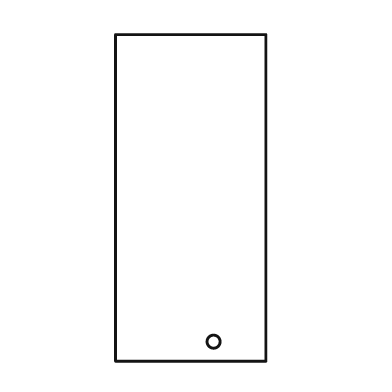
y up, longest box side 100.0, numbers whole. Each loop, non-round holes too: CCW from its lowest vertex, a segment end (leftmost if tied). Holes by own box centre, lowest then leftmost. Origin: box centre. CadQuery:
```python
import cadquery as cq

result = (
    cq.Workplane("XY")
    .moveTo(-23.0, -50.0)
    .lineTo(23.0, -50.0)
    .lineTo(23.0, 50.0)
    .lineTo(-23.0, 50.0)
    .close()
    .moveTo(7.0, -44.0)
    .circle(2.0)
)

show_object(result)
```